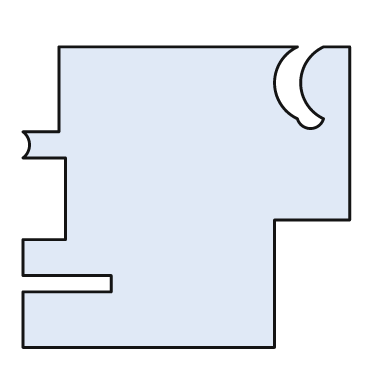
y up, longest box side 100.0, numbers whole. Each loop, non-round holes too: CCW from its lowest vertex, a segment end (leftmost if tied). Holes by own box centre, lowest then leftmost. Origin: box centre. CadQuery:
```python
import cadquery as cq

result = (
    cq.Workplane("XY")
    .moveTo(-50.0, -46.0)
    .lineTo(27.0, -46.0)
    .lineTo(27.0, -7.0)
    .lineTo(50.0, -7.0)
    .lineTo(50.0, 46.0)
    .lineTo(42.0, 46.0)
    .threePointArc((35.0, 35.0), (42.0, 24.0))
    .threePointArc((38.0, 21.0), (34.0, 24.0))
    .threePointArc((27.0, 35.0), (34.0, 46.0))
    .lineTo(-39.0, 46.0)
    .lineTo(-39.0, 20.0)
    .lineTo(-50.0, 20.0)
    .threePointArc((-48.0, 16.0), (-50.0, 12.0))
    .lineTo(-37.0, 12.0)
    .lineTo(-37.0, -13.0)
    .lineTo(-50.0, -13.0)
    .lineTo(-50.0, -24.0)
    .lineTo(-23.0, -24.0)
    .lineTo(-23.0, -29.0)
    .lineTo(-50.0, -29.0)
    .close()
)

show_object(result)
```